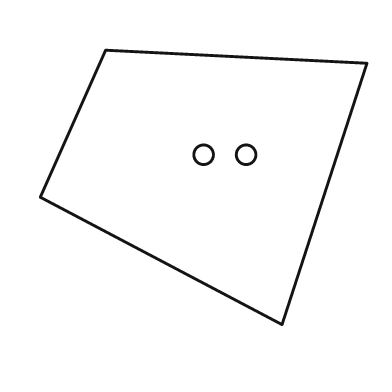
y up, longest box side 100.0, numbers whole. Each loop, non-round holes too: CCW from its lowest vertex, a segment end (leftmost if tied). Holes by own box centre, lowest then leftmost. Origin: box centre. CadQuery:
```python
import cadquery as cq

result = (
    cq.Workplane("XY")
    .moveTo(24.0, -42.0)
    .lineTo(50.0, 38.0)
    .lineTo(-30.0, 42.0)
    .lineTo(-50.0, -3.0)
    .close()
    .moveTo(0.0, 10.0)
    .circle(3.0)
    .moveTo(13.0, 10.0)
    .circle(3.0)
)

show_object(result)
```